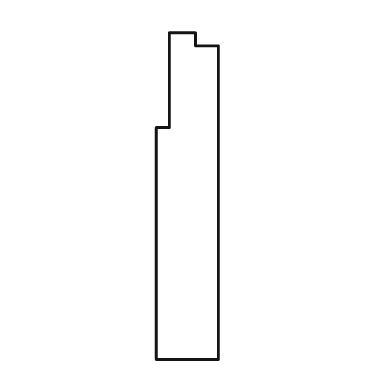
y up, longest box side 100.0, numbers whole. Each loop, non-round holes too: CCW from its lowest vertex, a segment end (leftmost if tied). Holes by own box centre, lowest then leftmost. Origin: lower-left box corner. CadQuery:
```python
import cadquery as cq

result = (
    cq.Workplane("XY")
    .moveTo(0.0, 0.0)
    .lineTo(19.0, 0.0)
    .lineTo(19.0, 96.0)
    .lineTo(12.0, 96.0)
    .lineTo(12.0, 100.0)
    .lineTo(4.0, 100.0)
    .lineTo(4.0, 71.0)
    .lineTo(0.0, 71.0)
    .close()
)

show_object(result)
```